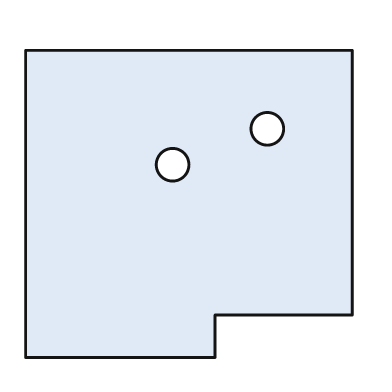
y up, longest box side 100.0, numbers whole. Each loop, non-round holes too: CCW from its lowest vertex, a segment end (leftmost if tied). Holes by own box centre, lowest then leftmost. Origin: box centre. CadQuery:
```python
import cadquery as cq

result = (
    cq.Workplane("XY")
    .moveTo(-50.0, -47.0)
    .lineTo(8.0, -47.0)
    .lineTo(8.0, -34.0)
    .lineTo(50.0, -34.0)
    .lineTo(50.0, 47.0)
    .lineTo(-50.0, 47.0)
    .close()
    .moveTo(-5.0, 12.0)
    .circle(5.0)
    .moveTo(24.0, 23.0)
    .circle(5.0)
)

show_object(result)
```